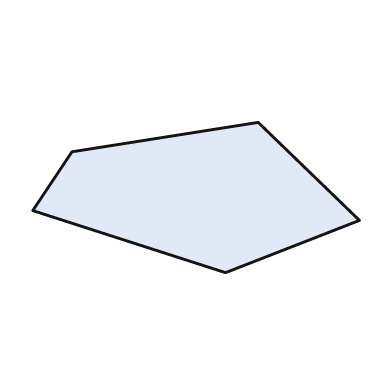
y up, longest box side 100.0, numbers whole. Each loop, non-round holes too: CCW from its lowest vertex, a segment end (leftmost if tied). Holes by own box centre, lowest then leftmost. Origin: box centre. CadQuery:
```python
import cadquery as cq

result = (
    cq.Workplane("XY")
    .moveTo(9.0, -23.0)
    .lineTo(50.0, -7.0)
    .lineTo(19.0, 23.0)
    .lineTo(-38.0, 14.0)
    .lineTo(-50.0, -4.0)
    .close()
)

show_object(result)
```